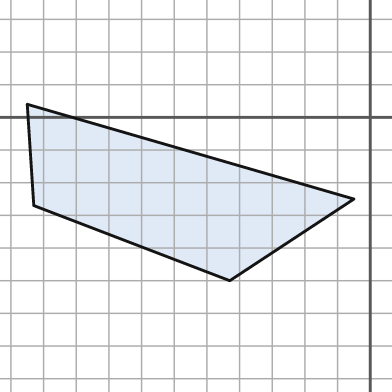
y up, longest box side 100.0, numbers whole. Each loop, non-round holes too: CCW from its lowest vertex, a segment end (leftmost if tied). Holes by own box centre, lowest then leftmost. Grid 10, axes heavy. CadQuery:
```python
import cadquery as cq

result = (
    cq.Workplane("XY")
    .moveTo(-43.0, -50.0)
    .lineTo(-5.0, -25.0)
    .lineTo(-105.0, 4.0)
    .lineTo(-103.0, -27.0)
    .close()
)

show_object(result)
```